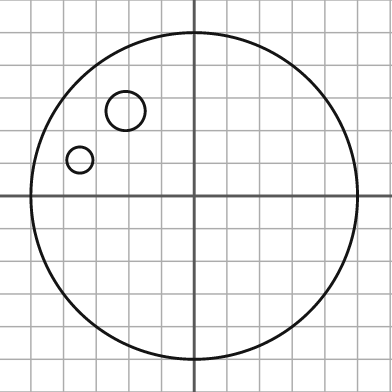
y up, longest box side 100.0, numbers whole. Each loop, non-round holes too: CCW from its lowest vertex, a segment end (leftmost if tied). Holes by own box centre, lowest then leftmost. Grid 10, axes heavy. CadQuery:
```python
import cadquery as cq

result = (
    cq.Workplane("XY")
    .moveTo(0.0, 0.0)
    .circle(50.0)
    .moveTo(-35.0, 11.0)
    .circle(4.0)
    .moveTo(-21.0, 26.0)
    .circle(6.0)
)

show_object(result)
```